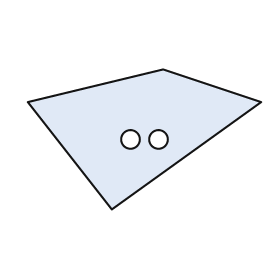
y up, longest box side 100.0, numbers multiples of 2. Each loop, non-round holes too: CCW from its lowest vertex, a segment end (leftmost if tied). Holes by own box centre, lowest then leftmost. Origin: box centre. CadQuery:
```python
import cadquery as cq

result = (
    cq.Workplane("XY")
    .moveTo(-14.0, -30.0)
    .lineTo(50.0, 16.0)
    .lineTo(8.0, 30.0)
    .lineTo(-50.0, 16.0)
    .close()
    .moveTo(-6.0, 0.0)
    .circle(4.0)
    .moveTo(6.0, 0.0)
    .circle(4.0)
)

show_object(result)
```